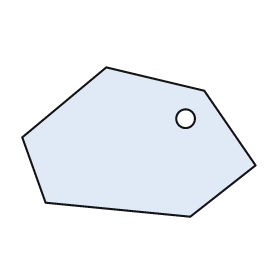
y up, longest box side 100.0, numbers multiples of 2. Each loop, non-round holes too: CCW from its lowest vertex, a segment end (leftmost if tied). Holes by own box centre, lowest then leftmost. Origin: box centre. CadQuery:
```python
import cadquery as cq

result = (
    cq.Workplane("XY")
    .moveTo(22.0, -32.0)
    .lineTo(50.0, -10.0)
    .lineTo(28.0, 22.0)
    .lineTo(-14.0, 32.0)
    .lineTo(-50.0, 2.0)
    .lineTo(-40.0, -26.0)
    .close()
    .moveTo(20.0, 10.0)
    .circle(4.0)
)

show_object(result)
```